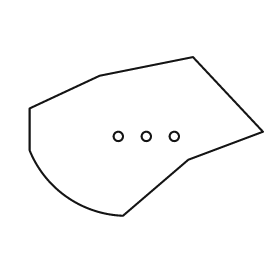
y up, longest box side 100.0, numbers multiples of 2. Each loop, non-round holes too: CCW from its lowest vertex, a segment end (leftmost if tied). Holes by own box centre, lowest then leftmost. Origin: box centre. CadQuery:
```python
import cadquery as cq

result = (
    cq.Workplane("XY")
    .moveTo(-10.0, -34.0)
    .lineTo(18.0, -10.0)
    .lineTo(50.0, 2.0)
    .lineTo(20.0, 34.0)
    .lineTo(-20.0, 26.0)
    .lineTo(-50.0, 12.0)
    .lineTo(-50.0, -6.0)
    .threePointArc((-34.0, -26.0), (-10.0, -34.0))
    .close()
    .moveTo(-12.0, 0.0)
    .circle(2.0)
    .moveTo(0.0, 0.0)
    .circle(2.0)
    .moveTo(12.0, 0.0)
    .circle(2.0)
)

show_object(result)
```